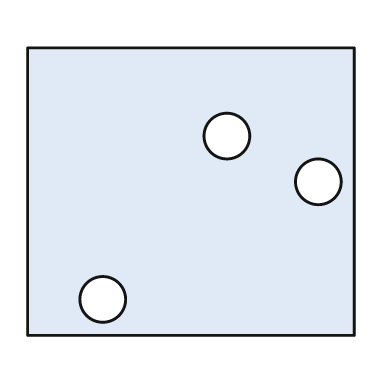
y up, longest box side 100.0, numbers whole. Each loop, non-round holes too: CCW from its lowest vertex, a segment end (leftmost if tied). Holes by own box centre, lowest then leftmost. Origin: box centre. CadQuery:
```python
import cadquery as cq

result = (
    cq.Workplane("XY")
    .moveTo(-50.0, -44.0)
    .lineTo(50.0, -44.0)
    .lineTo(50.0, 44.0)
    .lineTo(-50.0, 44.0)
    .close()
    .moveTo(-27.0, -33.0)
    .circle(7.0)
    .moveTo(39.0, 3.0)
    .circle(7.0)
    .moveTo(11.0, 17.0)
    .circle(7.0)
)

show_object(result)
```